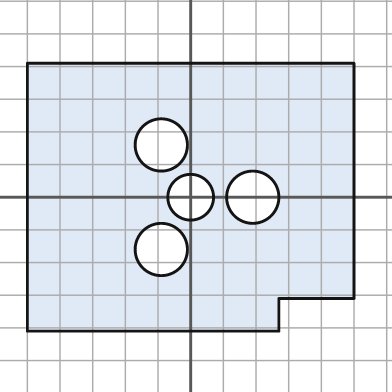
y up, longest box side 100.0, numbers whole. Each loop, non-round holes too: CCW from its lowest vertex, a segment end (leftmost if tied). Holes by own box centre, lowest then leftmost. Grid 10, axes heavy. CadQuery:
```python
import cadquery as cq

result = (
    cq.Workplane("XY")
    .moveTo(-50.0, -41.0)
    .lineTo(27.0, -41.0)
    .lineTo(27.0, -31.0)
    .lineTo(50.0, -31.0)
    .lineTo(50.0, 41.0)
    .lineTo(-50.0, 41.0)
    .close()
    .moveTo(-9.0, -16.0)
    .circle(8.0)
    .moveTo(0.0, 0.0)
    .circle(7.0)
    .moveTo(19.0, 0.0)
    .circle(8.0)
    .moveTo(-9.0, 16.0)
    .circle(8.0)
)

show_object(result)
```